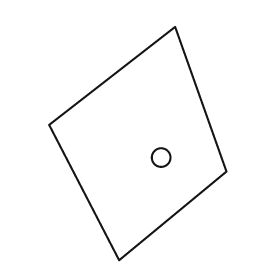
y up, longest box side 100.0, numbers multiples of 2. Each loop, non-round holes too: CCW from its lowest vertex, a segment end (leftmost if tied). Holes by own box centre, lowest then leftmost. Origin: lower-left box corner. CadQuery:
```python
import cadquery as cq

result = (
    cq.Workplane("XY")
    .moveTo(30.0, 0.0)
    .lineTo(76.0, 38.0)
    .lineTo(54.0, 100.0)
    .lineTo(0.0, 58.0)
    .close()
    .moveTo(48.0, 44.0)
    .circle(4.0)
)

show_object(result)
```